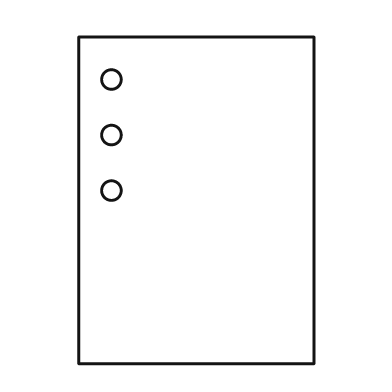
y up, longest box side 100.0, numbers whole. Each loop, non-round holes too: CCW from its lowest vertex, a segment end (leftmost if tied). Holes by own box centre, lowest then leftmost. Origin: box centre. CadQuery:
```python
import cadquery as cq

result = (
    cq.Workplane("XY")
    .moveTo(-36.0, -50.0)
    .lineTo(36.0, -50.0)
    .lineTo(36.0, 50.0)
    .lineTo(-36.0, 50.0)
    .close()
    .moveTo(-26.0, 3.0)
    .circle(3.0)
    .moveTo(-26.0, 20.0)
    .circle(3.0)
    .moveTo(-26.0, 37.0)
    .circle(3.0)
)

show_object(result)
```